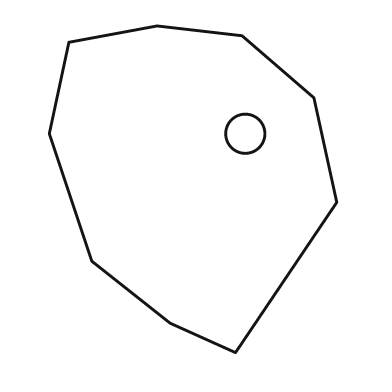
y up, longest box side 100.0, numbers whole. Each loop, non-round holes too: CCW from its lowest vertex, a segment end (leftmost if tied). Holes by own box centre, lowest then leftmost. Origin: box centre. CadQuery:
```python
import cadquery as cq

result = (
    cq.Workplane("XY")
    .moveTo(13.0, -50.0)
    .lineTo(44.0, -4.0)
    .lineTo(37.0, 28.0)
    .lineTo(15.0, 47.0)
    .lineTo(-11.0, 50.0)
    .lineTo(-38.0, 45.0)
    .lineTo(-44.0, 17.0)
    .lineTo(-31.0, -22.0)
    .lineTo(-7.0, -41.0)
    .close()
    .moveTo(16.0, 17.0)
    .circle(6.0)
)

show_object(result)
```